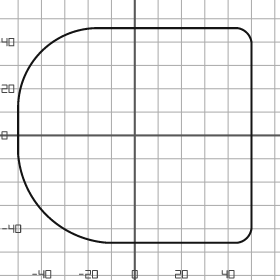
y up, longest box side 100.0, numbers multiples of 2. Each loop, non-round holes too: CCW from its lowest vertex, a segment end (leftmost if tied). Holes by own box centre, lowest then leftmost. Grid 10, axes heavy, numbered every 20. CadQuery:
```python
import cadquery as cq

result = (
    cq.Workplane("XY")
    .moveTo(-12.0, -46.0)
    .lineTo(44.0, -46.0)
    .threePointArc((48.0, -44.0), (50.0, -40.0))
    .lineTo(50.0, 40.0)
    .threePointArc((48.0, 44.0), (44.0, 46.0))
    .lineTo(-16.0, 46.0)
    .threePointArc((-40.0, 36.0), (-50.0, 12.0))
    .lineTo(-50.0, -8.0)
    .threePointArc((-38.0, -34.0), (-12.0, -46.0))
    .close()
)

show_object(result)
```